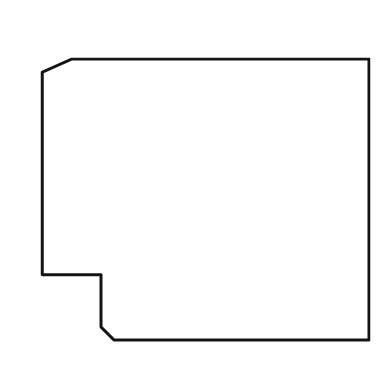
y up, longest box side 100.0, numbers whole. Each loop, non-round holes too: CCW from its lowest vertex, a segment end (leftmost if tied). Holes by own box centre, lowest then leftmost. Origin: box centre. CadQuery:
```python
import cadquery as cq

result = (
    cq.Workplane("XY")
    .moveTo(-28.0, -43.0)
    .lineTo(50.0, -43.0)
    .lineTo(50.0, 43.0)
    .lineTo(-41.0, 43.0)
    .lineTo(-50.0, 39.0)
    .lineTo(-50.0, -23.0)
    .lineTo(-32.0, -23.0)
    .lineTo(-32.0, -39.0)
    .close()
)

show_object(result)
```